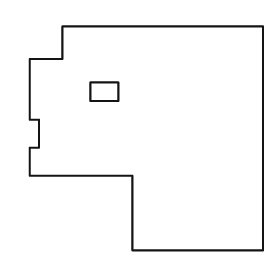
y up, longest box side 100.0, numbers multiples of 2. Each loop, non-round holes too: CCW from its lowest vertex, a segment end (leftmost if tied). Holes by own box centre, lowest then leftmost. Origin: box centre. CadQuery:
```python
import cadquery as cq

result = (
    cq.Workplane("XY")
    .moveTo(-6.0, -48.0)
    .lineTo(50.0, -48.0)
    .lineTo(50.0, 48.0)
    .lineTo(-36.0, 48.0)
    .lineTo(-36.0, 34.0)
    .lineTo(-50.0, 34.0)
    .lineTo(-50.0, 8.0)
    .lineTo(-46.0, 8.0)
    .lineTo(-46.0, -4.0)
    .lineTo(-50.0, -4.0)
    .lineTo(-50.0, -16.0)
    .lineTo(-6.0, -16.0)
    .close()
    .moveTo(-24.0, 16.0)
    .lineTo(-12.0, 16.0)
    .lineTo(-12.0, 24.0)
    .lineTo(-24.0, 24.0)
    .close()
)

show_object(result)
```